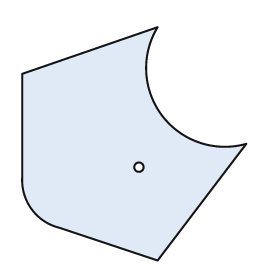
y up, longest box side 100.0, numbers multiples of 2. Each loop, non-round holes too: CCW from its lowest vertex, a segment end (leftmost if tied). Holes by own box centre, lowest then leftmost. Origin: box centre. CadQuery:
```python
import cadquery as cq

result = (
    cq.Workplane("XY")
    .moveTo(10.0, -50.0)
    .lineTo(48.0, 0.0)
    .threePointArc((12.0, 12.0), (10.0, 50.0))
    .lineTo(-48.0, 30.0)
    .lineTo(-48.0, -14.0)
    .threePointArc((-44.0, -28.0), (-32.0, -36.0))
    .close()
    .moveTo(2.0, -10.0)
    .circle(2.0)
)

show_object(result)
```